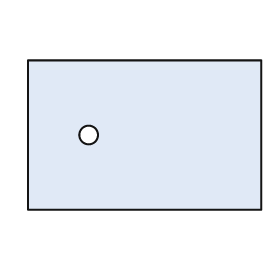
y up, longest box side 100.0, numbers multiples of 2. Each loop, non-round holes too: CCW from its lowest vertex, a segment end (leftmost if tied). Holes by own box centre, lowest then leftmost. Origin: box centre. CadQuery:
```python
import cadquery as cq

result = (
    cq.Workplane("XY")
    .moveTo(-50.0, -32.0)
    .lineTo(50.0, -32.0)
    .lineTo(50.0, 32.0)
    .lineTo(-50.0, 32.0)
    .close()
    .moveTo(-24.0, 0.0)
    .circle(4.0)
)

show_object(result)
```